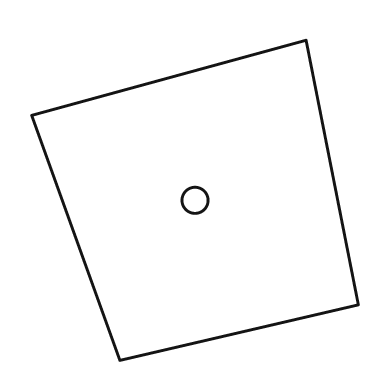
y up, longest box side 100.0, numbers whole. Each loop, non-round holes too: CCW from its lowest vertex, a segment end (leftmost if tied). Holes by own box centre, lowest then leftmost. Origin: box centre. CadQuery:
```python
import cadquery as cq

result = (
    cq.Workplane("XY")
    .moveTo(-23.0, -49.0)
    .lineTo(50.0, -32.0)
    .lineTo(34.0, 49.0)
    .lineTo(-50.0, 26.0)
    .close()
    .moveTo(0.0, 0.0)
    .circle(4.0)
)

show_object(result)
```